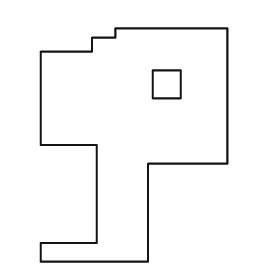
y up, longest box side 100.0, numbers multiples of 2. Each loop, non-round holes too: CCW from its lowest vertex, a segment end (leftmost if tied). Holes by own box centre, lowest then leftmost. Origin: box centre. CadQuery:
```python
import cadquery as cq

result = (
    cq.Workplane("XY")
    .moveTo(-40.0, -50.0)
    .lineTo(6.0, -50.0)
    .lineTo(6.0, -8.0)
    .lineTo(40.0, -8.0)
    .lineTo(40.0, 50.0)
    .lineTo(-8.0, 50.0)
    .lineTo(-8.0, 46.0)
    .lineTo(-18.0, 46.0)
    .lineTo(-18.0, 40.0)
    .lineTo(-40.0, 40.0)
    .lineTo(-40.0, 0.0)
    .lineTo(-16.0, 0.0)
    .lineTo(-16.0, -42.0)
    .lineTo(-40.0, -42.0)
    .close()
    .moveTo(8.0, 20.0)
    .lineTo(20.0, 20.0)
    .lineTo(20.0, 32.0)
    .lineTo(8.0, 32.0)
    .close()
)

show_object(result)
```